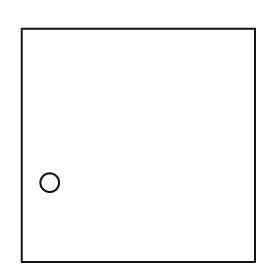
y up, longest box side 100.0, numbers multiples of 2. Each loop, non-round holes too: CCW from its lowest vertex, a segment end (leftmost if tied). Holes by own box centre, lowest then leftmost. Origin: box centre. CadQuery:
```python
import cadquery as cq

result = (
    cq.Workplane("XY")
    .moveTo(-50.0, -50.0)
    .lineTo(50.0, -50.0)
    .lineTo(50.0, 50.0)
    .lineTo(-50.0, 50.0)
    .close()
    .moveTo(-38.0, -16.0)
    .circle(4.0)
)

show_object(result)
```